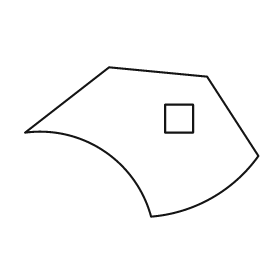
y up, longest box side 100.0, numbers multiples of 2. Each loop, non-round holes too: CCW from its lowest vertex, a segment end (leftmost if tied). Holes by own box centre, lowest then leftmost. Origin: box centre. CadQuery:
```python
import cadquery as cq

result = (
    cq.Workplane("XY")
    .moveTo(4.0, -32.0)
    .threePointArc((30.0, -24.0), (50.0, -6.0))
    .lineTo(28.0, 28.0)
    .lineTo(-14.0, 32.0)
    .lineTo(-50.0, 4.0)
    .threePointArc((-16.0, -4.0), (4.0, -32.0))
    .close()
    .moveTo(10.0, 4.0)
    .lineTo(22.0, 4.0)
    .lineTo(22.0, 16.0)
    .lineTo(10.0, 16.0)
    .close()
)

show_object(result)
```